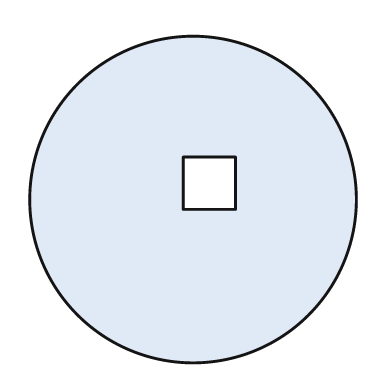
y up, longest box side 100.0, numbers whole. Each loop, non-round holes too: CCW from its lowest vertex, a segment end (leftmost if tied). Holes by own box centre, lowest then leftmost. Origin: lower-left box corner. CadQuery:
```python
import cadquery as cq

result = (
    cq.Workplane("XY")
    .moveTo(50.0, 50.0)
    .circle(50.0)
    .moveTo(47.0, 47.0)
    .lineTo(63.0, 47.0)
    .lineTo(63.0, 63.0)
    .lineTo(47.0, 63.0)
    .close()
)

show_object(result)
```